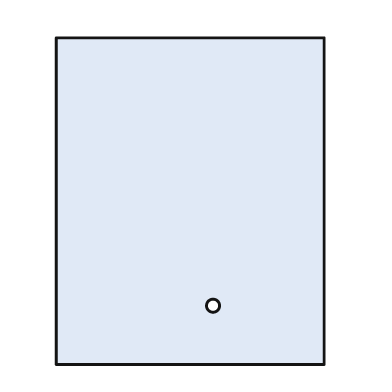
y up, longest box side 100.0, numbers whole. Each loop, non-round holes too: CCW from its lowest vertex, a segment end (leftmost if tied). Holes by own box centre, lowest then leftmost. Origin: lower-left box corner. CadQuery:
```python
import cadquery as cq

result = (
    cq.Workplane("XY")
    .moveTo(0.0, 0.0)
    .lineTo(82.0, 0.0)
    .lineTo(82.0, 100.0)
    .lineTo(0.0, 100.0)
    .close()
    .moveTo(48.0, 18.0)
    .circle(2.0)
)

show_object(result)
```